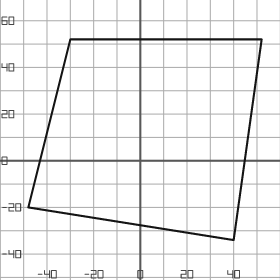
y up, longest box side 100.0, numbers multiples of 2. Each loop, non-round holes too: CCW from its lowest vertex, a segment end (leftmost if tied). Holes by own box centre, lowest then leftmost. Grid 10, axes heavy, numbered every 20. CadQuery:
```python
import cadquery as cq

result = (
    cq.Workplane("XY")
    .moveTo(40.0, -34.0)
    .lineTo(52.0, 52.0)
    .lineTo(-30.0, 52.0)
    .lineTo(-48.0, -20.0)
    .close()
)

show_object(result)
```